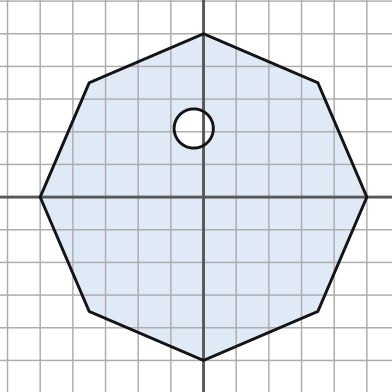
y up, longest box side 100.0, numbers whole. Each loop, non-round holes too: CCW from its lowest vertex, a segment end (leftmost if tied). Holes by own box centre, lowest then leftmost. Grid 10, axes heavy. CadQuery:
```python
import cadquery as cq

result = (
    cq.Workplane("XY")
    .moveTo(0.0, -50.0)
    .lineTo(35.0, -35.0)
    .lineTo(50.0, 0.0)
    .lineTo(35.0, 35.0)
    .lineTo(0.0, 50.0)
    .lineTo(-35.0, 35.0)
    .lineTo(-50.0, 0.0)
    .lineTo(-35.0, -35.0)
    .close()
    .moveTo(-3.0, 21.0)
    .circle(6.0)
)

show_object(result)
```